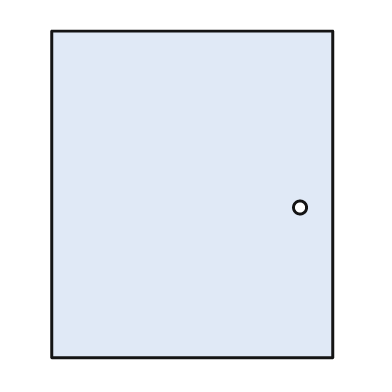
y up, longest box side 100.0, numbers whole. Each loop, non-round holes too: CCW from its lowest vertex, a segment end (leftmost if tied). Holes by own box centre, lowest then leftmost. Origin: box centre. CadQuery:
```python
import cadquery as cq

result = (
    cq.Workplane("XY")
    .moveTo(-43.0, -50.0)
    .lineTo(43.0, -50.0)
    .lineTo(43.0, 50.0)
    .lineTo(-43.0, 50.0)
    .close()
    .moveTo(33.0, -4.0)
    .circle(2.0)
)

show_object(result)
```